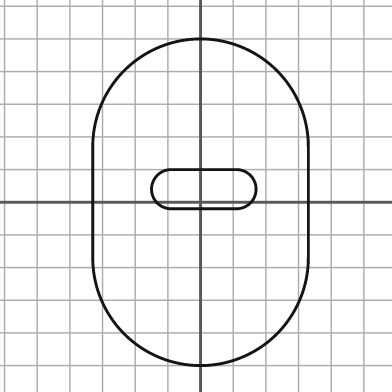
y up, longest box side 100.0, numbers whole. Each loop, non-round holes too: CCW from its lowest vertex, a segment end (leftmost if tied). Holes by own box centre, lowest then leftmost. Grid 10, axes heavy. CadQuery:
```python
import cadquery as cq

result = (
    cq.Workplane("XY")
    .moveTo(-33.0, -17.0)
    .threePointArc((0.0, -50.0), (33.0, -17.0))
    .lineTo(33.0, 17.0)
    .threePointArc((0.0, 50.0), (-33.0, 17.0))
    .close()
    .moveTo(-9.0, -2.0)
    .lineTo(11.0, -2.0)
    .threePointArc((17.0, 4.0), (11.0, 10.0))
    .lineTo(-9.0, 10.0)
    .threePointArc((-15.0, 4.0), (-9.0, -2.0))
    .close()
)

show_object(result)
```